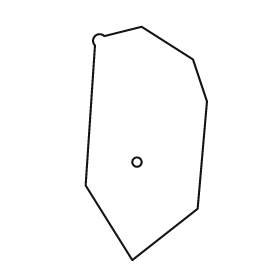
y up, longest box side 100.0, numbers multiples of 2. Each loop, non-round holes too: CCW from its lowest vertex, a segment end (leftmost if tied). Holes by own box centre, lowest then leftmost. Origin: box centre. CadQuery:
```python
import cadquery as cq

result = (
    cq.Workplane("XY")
    .moveTo(-6.0, -50.0)
    .lineTo(22.0, -28.0)
    .lineTo(26.0, 18.0)
    .lineTo(20.0, 36.0)
    .lineTo(-2.0, 50.0)
    .lineTo(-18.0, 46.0)
    .threePointArc((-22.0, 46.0), (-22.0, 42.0))
    .lineTo(-26.0, -18.0)
    .close()
    .moveTo(-4.0, -8.0)
    .circle(2.0)
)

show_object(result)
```